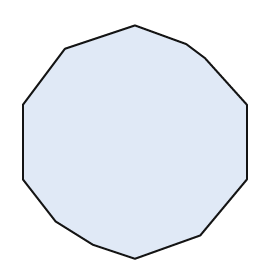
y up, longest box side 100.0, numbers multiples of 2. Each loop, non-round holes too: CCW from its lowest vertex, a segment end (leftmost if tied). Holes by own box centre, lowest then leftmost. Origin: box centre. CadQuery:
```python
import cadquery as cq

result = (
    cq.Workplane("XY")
    .moveTo(0.0, -50.0)
    .lineTo(28.0, -40.0)
    .lineTo(48.0, -16.0)
    .lineTo(48.0, 16.0)
    .lineTo(30.0, 36.0)
    .lineTo(22.0, 42.0)
    .lineTo(0.0, 50.0)
    .lineTo(-30.0, 40.0)
    .lineTo(-48.0, 16.0)
    .lineTo(-48.0, -16.0)
    .lineTo(-34.0, -34.0)
    .lineTo(-18.0, -44.0)
    .close()
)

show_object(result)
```